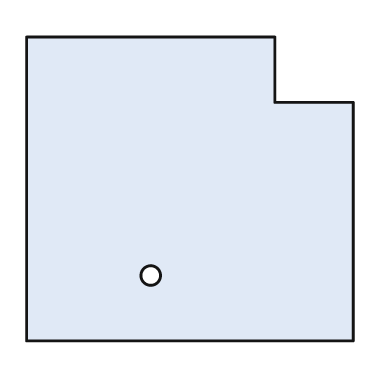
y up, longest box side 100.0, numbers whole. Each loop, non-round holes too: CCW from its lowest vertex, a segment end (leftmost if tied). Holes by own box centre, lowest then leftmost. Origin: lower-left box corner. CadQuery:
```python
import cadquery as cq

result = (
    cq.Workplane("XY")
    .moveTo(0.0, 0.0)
    .lineTo(100.0, 0.0)
    .lineTo(100.0, 73.0)
    .lineTo(76.0, 73.0)
    .lineTo(76.0, 93.0)
    .lineTo(0.0, 93.0)
    .close()
    .moveTo(38.0, 20.0)
    .circle(3.0)
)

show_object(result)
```